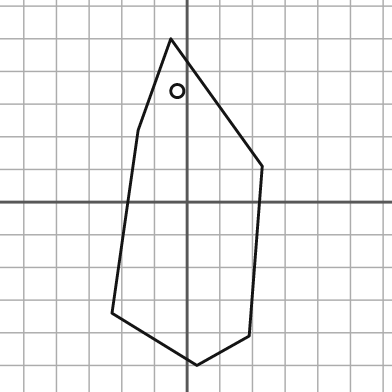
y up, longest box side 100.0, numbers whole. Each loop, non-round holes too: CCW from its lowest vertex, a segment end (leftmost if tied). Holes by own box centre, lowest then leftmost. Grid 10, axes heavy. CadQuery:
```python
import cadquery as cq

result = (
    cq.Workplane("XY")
    .moveTo(3.0, -50.0)
    .lineTo(19.0, -41.0)
    .lineTo(23.0, 11.0)
    .lineTo(-5.0, 50.0)
    .lineTo(-15.0, 22.0)
    .lineTo(-23.0, -34.0)
    .close()
    .moveTo(-3.0, 34.0)
    .circle(2.0)
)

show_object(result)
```